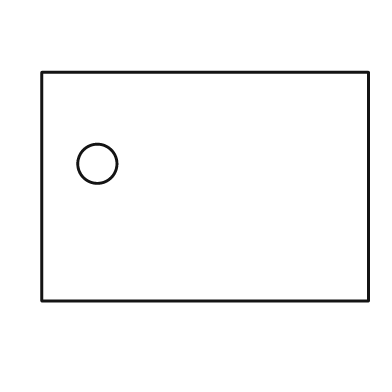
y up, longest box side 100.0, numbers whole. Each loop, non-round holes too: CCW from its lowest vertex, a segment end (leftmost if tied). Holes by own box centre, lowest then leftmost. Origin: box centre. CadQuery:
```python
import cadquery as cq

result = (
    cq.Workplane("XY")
    .moveTo(-50.0, -35.0)
    .lineTo(50.0, -35.0)
    .lineTo(50.0, 35.0)
    .lineTo(-50.0, 35.0)
    .close()
    .moveTo(-33.0, 7.0)
    .circle(6.0)
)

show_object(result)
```